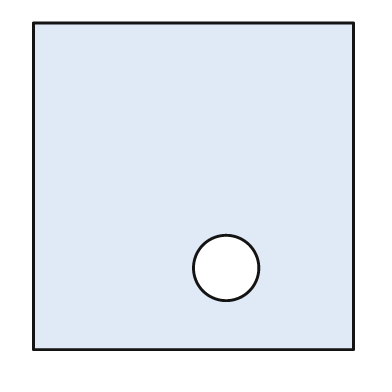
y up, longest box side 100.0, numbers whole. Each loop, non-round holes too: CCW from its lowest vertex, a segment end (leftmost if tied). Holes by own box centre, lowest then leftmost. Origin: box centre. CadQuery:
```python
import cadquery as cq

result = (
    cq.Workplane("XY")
    .moveTo(-49.0, -50.0)
    .lineTo(49.0, -50.0)
    .lineTo(49.0, 50.0)
    .lineTo(-49.0, 50.0)
    .close()
    .moveTo(10.0, -25.0)
    .circle(10.0)
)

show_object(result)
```